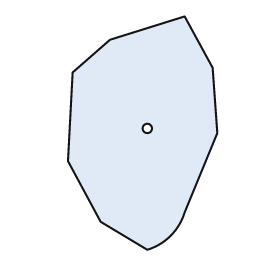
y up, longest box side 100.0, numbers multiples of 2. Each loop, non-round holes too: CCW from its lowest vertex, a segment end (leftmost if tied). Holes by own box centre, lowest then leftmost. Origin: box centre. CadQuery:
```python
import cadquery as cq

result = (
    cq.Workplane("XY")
    .moveTo(2.0, -50.0)
    .threePointArc((12.0, -44.0), (18.0, -34.0))
    .lineTo(32.0, 0.0)
    .lineTo(30.0, 28.0)
    .lineTo(18.0, 50.0)
    .lineTo(-14.0, 40.0)
    .lineTo(-30.0, 26.0)
    .lineTo(-32.0, -12.0)
    .lineTo(-18.0, -38.0)
    .close()
    .moveTo(2.0, 2.0)
    .circle(2.0)
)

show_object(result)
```